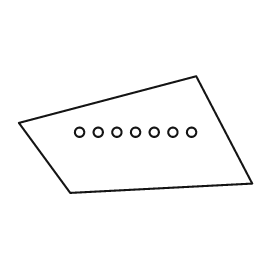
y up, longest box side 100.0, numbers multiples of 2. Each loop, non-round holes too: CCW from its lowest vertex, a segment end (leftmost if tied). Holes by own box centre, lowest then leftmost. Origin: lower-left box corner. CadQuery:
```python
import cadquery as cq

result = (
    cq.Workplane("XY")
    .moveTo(22.0, 0.0)
    .lineTo(100.0, 4.0)
    .lineTo(76.0, 50.0)
    .lineTo(0.0, 30.0)
    .close()
    .moveTo(26.0, 26.0)
    .circle(2.0)
    .moveTo(34.0, 26.0)
    .circle(2.0)
    .moveTo(42.0, 26.0)
    .circle(2.0)
    .moveTo(50.0, 26.0)
    .circle(2.0)
    .moveTo(58.0, 26.0)
    .circle(2.0)
    .moveTo(66.0, 26.0)
    .circle(2.0)
    .moveTo(74.0, 26.0)
    .circle(2.0)
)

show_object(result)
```